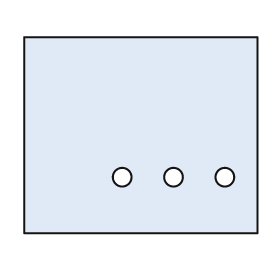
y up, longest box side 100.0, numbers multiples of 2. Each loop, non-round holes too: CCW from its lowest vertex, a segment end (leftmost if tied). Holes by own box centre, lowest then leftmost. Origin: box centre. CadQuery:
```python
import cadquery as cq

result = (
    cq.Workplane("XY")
    .moveTo(-50.0, -42.0)
    .lineTo(50.0, -42.0)
    .lineTo(50.0, 42.0)
    .lineTo(-50.0, 42.0)
    .close()
    .moveTo(-8.0, -18.0)
    .circle(4.0)
    .moveTo(14.0, -18.0)
    .circle(4.0)
    .moveTo(36.0, -18.0)
    .circle(4.0)
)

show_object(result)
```